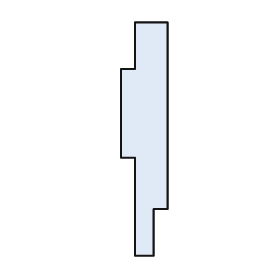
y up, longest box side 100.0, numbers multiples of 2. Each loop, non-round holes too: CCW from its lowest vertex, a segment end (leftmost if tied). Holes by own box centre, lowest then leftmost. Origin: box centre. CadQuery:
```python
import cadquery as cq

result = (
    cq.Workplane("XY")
    .moveTo(-4.0, -50.0)
    .lineTo(4.0, -50.0)
    .lineTo(4.0, -30.0)
    .lineTo(10.0, -30.0)
    .lineTo(10.0, 50.0)
    .lineTo(-4.0, 50.0)
    .lineTo(-4.0, 30.0)
    .lineTo(-10.0, 30.0)
    .lineTo(-10.0, -8.0)
    .lineTo(-4.0, -8.0)
    .close()
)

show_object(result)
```